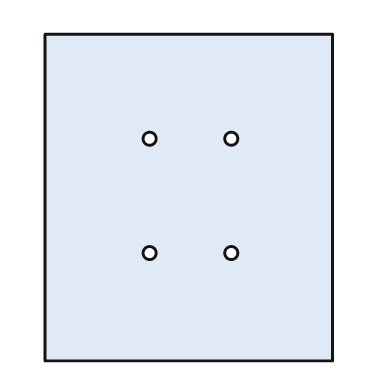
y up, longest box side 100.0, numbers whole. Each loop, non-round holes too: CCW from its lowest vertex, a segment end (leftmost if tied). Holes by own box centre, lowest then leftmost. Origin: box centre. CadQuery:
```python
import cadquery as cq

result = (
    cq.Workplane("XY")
    .moveTo(-44.0, -50.0)
    .lineTo(44.0, -50.0)
    .lineTo(44.0, 50.0)
    .lineTo(-44.0, 50.0)
    .close()
    .moveTo(-12.0, -17.0)
    .circle(2.0)
    .moveTo(13.0, -17.0)
    .circle(2.0)
    .moveTo(-12.0, 18.0)
    .circle(2.0)
    .moveTo(13.0, 18.0)
    .circle(2.0)
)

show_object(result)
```